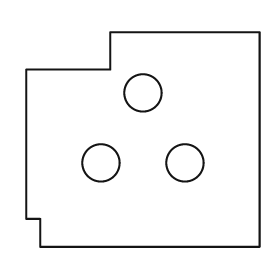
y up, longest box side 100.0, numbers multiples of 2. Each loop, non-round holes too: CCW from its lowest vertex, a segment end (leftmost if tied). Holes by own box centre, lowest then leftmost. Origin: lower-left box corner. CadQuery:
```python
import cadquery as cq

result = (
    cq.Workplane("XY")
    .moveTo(6.0, 0.0)
    .lineTo(100.0, 0.0)
    .lineTo(100.0, 92.0)
    .lineTo(36.0, 92.0)
    .lineTo(36.0, 76.0)
    .lineTo(0.0, 76.0)
    .lineTo(0.0, 12.0)
    .lineTo(6.0, 12.0)
    .close()
    .moveTo(32.0, 36.0)
    .circle(8.0)
    .moveTo(68.0, 36.0)
    .circle(8.0)
    .moveTo(50.0, 66.0)
    .circle(8.0)
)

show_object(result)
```